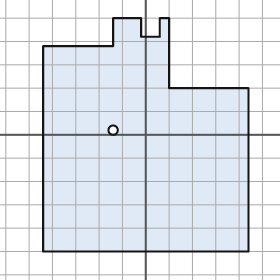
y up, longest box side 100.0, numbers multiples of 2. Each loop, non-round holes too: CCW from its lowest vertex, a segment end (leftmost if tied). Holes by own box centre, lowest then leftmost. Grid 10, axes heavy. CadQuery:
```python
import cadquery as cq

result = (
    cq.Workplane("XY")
    .moveTo(-44.0, -50.0)
    .lineTo(44.0, -50.0)
    .lineTo(44.0, 20.0)
    .lineTo(10.0, 20.0)
    .lineTo(10.0, 50.0)
    .lineTo(6.0, 50.0)
    .lineTo(6.0, 42.0)
    .lineTo(-2.0, 42.0)
    .lineTo(-2.0, 50.0)
    .lineTo(-14.0, 50.0)
    .lineTo(-14.0, 38.0)
    .lineTo(-44.0, 38.0)
    .close()
    .moveTo(-14.0, 2.0)
    .circle(2.0)
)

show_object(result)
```